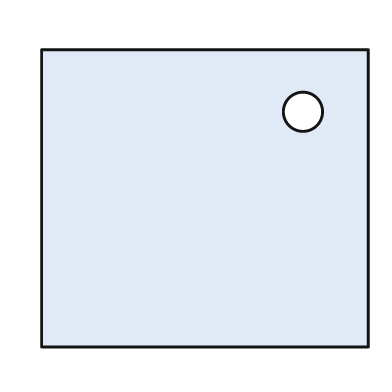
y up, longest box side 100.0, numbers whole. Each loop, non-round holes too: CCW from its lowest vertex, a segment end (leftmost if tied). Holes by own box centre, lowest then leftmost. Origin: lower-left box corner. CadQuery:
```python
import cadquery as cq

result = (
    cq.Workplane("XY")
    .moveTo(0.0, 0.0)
    .lineTo(100.0, 0.0)
    .lineTo(100.0, 91.0)
    .lineTo(0.0, 91.0)
    .close()
    .moveTo(80.0, 72.0)
    .circle(6.0)
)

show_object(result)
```